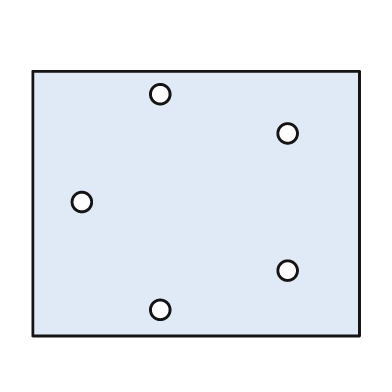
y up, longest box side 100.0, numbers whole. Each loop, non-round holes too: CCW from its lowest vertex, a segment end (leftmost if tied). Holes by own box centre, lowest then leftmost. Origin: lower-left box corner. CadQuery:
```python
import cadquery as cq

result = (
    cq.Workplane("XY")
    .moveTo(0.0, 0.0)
    .lineTo(100.0, 0.0)
    .lineTo(100.0, 81.0)
    .lineTo(0.0, 81.0)
    .close()
    .moveTo(39.0, 8.0)
    .circle(3.0)
    .moveTo(78.0, 20.0)
    .circle(3.0)
    .moveTo(15.0, 41.0)
    .circle(3.0)
    .moveTo(78.0, 62.0)
    .circle(3.0)
    .moveTo(39.0, 74.0)
    .circle(3.0)
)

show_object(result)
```